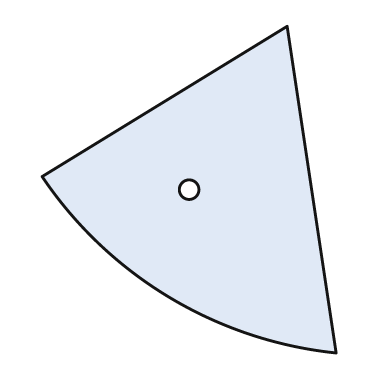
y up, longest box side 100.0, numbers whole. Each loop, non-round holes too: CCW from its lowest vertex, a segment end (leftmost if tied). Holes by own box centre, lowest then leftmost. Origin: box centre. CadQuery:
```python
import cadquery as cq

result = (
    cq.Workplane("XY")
    .moveTo(45.0, -50.0)
    .lineTo(30.0, 50.0)
    .lineTo(-45.0, 4.0)
    .threePointArc((-6.0, -33.0), (45.0, -50.0))
    .close()
    .moveTo(0.0, 0.0)
    .circle(3.0)
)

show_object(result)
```